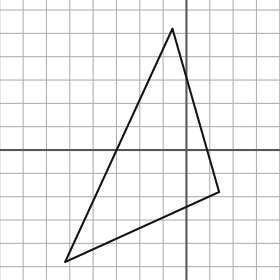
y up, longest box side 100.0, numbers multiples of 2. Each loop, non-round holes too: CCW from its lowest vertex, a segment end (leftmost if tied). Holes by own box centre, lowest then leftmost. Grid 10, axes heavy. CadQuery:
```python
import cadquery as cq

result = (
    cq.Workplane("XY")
    .moveTo(-52.0, -48.0)
    .lineTo(14.0, -18.0)
    .lineTo(-6.0, 52.0)
    .close()
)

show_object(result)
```